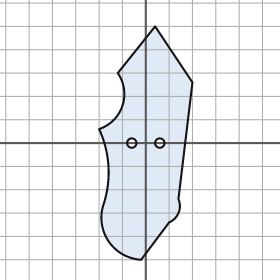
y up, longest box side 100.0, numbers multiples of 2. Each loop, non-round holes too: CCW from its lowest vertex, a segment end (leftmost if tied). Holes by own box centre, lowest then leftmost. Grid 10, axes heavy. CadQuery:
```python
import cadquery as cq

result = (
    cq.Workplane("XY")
    .moveTo(-2.0, -50.0)
    .lineTo(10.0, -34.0)
    .threePointArc((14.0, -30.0), (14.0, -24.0))
    .lineTo(20.0, 26.0)
    .lineTo(4.0, 50.0)
    .lineTo(-12.0, 30.0)
    .threePointArc((-10.0, 16.0), (-20.0, 6.0))
    .threePointArc((-16.0, -10.0), (-18.0, -26.0))
    .threePointArc((-16.0, -42.0), (-2.0, -50.0))
    .close()
    .moveTo(-6.0, 0.0)
    .circle(2.0)
    .moveTo(6.0, 0.0)
    .circle(2.0)
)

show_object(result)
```